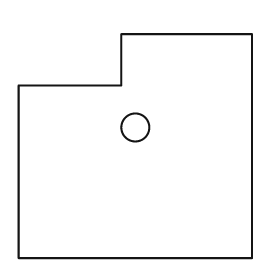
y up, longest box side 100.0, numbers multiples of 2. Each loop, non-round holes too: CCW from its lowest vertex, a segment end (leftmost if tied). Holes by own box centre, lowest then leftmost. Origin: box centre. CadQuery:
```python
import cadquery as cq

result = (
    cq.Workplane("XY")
    .moveTo(-50.0, -48.0)
    .lineTo(50.0, -48.0)
    .lineTo(50.0, 48.0)
    .lineTo(-6.0, 48.0)
    .lineTo(-6.0, 26.0)
    .lineTo(-50.0, 26.0)
    .close()
    .moveTo(0.0, 8.0)
    .circle(6.0)
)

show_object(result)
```